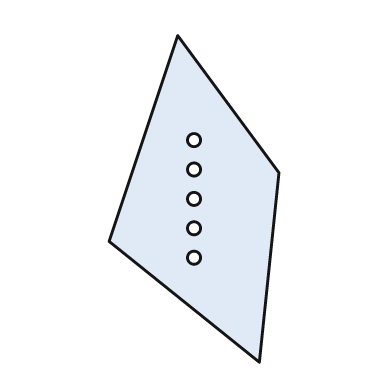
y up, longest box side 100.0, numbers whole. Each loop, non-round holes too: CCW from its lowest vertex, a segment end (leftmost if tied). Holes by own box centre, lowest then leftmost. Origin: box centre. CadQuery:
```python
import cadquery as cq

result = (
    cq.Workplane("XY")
    .moveTo(20.0, -50.0)
    .lineTo(26.0, 8.0)
    .lineTo(-5.0, 50.0)
    .lineTo(-26.0, -13.0)
    .close()
    .moveTo(0.0, -18.0)
    .circle(2.0)
    .moveTo(0.0, -9.0)
    .circle(2.0)
    .moveTo(0.0, 0.0)
    .circle(2.0)
    .moveTo(0.0, 9.0)
    .circle(2.0)
    .moveTo(0.0, 18.0)
    .circle(2.0)
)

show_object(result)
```